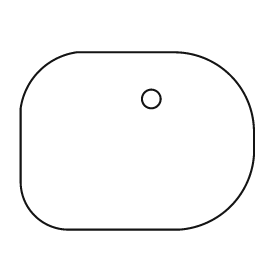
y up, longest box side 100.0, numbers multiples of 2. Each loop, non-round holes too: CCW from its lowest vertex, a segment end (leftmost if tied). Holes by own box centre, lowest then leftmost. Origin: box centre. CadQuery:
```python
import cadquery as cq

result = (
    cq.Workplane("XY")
    .moveTo(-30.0, -38.0)
    .lineTo(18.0, -38.0)
    .threePointArc((40.0, -28.0), (50.0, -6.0))
    .lineTo(50.0, 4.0)
    .threePointArc((40.0, 28.0), (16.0, 38.0))
    .lineTo(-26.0, 38.0)
    .threePointArc((-42.0, 30.0), (-50.0, 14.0))
    .lineTo(-50.0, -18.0)
    .threePointArc((-44.0, -32.0), (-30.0, -38.0))
    .close()
    .moveTo(6.0, 18.0)
    .circle(4.0)
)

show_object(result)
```